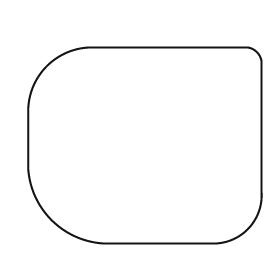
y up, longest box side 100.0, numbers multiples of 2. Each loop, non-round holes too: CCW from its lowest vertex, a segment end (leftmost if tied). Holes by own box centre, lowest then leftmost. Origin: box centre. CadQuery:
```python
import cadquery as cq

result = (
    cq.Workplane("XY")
    .moveTo(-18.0, -42.0)
    .lineTo(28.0, -42.0)
    .threePointArc((44.0, -36.0), (50.0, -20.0))
    .lineTo(50.0, 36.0)
    .threePointArc((48.0, 40.0), (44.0, 42.0))
    .lineTo(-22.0, 42.0)
    .threePointArc((-42.0, 34.0), (-50.0, 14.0))
    .lineTo(-50.0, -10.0)
    .threePointArc((-40.0, -32.0), (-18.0, -42.0))
    .close()
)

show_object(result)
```